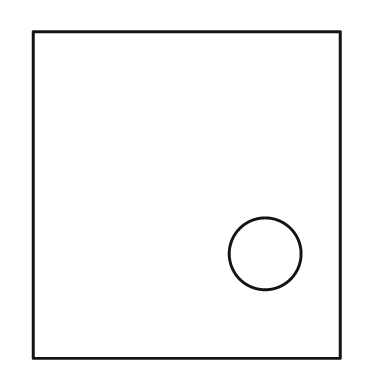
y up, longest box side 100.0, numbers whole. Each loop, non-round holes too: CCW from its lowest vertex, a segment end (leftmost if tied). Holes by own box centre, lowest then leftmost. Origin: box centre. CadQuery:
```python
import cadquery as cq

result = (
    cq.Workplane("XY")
    .moveTo(-47.0, -50.0)
    .lineTo(47.0, -50.0)
    .lineTo(47.0, 50.0)
    .lineTo(-47.0, 50.0)
    .close()
    .moveTo(24.0, -18.0)
    .circle(11.0)
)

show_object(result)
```